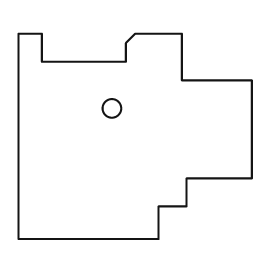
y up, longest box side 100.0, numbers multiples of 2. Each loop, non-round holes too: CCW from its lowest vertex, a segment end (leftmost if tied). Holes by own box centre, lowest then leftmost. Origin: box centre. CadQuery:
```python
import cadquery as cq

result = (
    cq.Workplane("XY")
    .moveTo(-50.0, -44.0)
    .lineTo(10.0, -44.0)
    .lineTo(10.0, -30.0)
    .lineTo(22.0, -30.0)
    .lineTo(22.0, -18.0)
    .lineTo(50.0, -18.0)
    .lineTo(50.0, 24.0)
    .lineTo(20.0, 24.0)
    .lineTo(20.0, 44.0)
    .lineTo(0.0, 44.0)
    .lineTo(-4.0, 40.0)
    .lineTo(-4.0, 32.0)
    .lineTo(-40.0, 32.0)
    .lineTo(-40.0, 44.0)
    .lineTo(-50.0, 44.0)
    .close()
    .moveTo(-10.0, 12.0)
    .circle(4.0)
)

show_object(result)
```